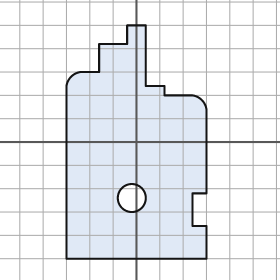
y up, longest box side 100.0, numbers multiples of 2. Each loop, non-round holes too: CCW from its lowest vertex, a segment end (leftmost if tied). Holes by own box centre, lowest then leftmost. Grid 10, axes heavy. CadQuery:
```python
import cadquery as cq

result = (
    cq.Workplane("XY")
    .moveTo(-30.0, -50.0)
    .lineTo(30.0, -50.0)
    .lineTo(30.0, -36.0)
    .lineTo(24.0, -36.0)
    .lineTo(24.0, -22.0)
    .lineTo(30.0, -22.0)
    .lineTo(30.0, 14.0)
    .threePointArc((28.0, 18.0), (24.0, 20.0))
    .lineTo(12.0, 20.0)
    .lineTo(12.0, 24.0)
    .lineTo(4.0, 24.0)
    .lineTo(4.0, 50.0)
    .lineTo(-4.0, 50.0)
    .lineTo(-4.0, 42.0)
    .lineTo(-16.0, 42.0)
    .lineTo(-16.0, 30.0)
    .lineTo(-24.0, 30.0)
    .threePointArc((-28.0, 28.0), (-30.0, 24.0))
    .close()
    .moveTo(-2.0, -24.0)
    .circle(6.0)
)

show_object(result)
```